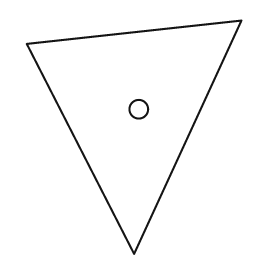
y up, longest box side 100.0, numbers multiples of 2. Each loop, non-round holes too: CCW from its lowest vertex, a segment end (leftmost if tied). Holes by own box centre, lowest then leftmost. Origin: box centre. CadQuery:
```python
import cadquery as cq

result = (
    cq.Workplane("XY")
    .moveTo(0.0, -50.0)
    .lineTo(46.0, 50.0)
    .lineTo(-46.0, 40.0)
    .close()
    .moveTo(2.0, 12.0)
    .circle(4.0)
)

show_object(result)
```